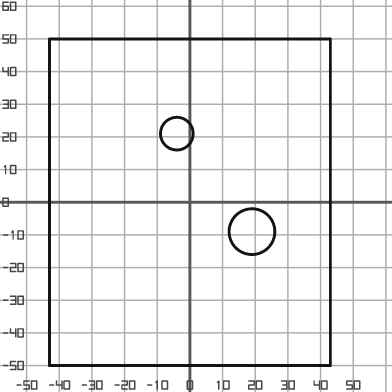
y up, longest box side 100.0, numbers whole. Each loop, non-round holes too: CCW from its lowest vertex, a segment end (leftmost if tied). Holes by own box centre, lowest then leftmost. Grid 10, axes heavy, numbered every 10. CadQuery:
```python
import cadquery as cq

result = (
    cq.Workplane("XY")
    .moveTo(-43.0, -50.0)
    .lineTo(43.0, -50.0)
    .lineTo(43.0, 50.0)
    .lineTo(-43.0, 50.0)
    .close()
    .moveTo(19.0, -9.0)
    .circle(7.0)
    .moveTo(-4.0, 21.0)
    .circle(5.0)
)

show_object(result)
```